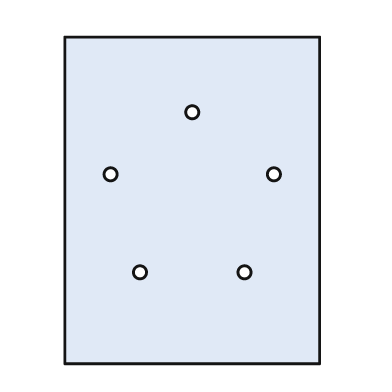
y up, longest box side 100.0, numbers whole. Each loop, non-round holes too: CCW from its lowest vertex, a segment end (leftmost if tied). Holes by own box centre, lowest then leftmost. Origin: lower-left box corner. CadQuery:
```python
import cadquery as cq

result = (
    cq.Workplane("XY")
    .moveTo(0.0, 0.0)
    .lineTo(78.0, 0.0)
    .lineTo(78.0, 100.0)
    .lineTo(0.0, 100.0)
    .close()
    .moveTo(23.0, 28.0)
    .circle(2.0)
    .moveTo(55.0, 28.0)
    .circle(2.0)
    .moveTo(14.0, 58.0)
    .circle(2.0)
    .moveTo(64.0, 58.0)
    .circle(2.0)
    .moveTo(39.0, 77.0)
    .circle(2.0)
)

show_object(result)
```